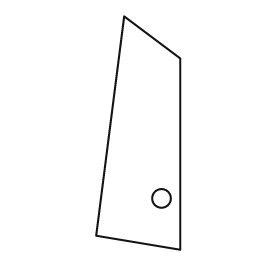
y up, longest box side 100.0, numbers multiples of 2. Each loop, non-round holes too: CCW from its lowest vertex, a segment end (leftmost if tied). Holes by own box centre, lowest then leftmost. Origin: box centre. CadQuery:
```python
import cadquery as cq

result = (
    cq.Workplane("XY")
    .moveTo(18.0, -50.0)
    .lineTo(18.0, 32.0)
    .lineTo(-6.0, 50.0)
    .lineTo(-18.0, -44.0)
    .close()
    .moveTo(10.0, -28.0)
    .circle(4.0)
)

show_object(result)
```